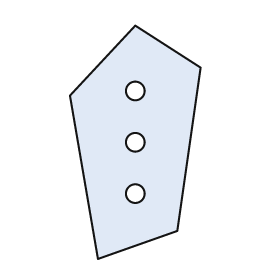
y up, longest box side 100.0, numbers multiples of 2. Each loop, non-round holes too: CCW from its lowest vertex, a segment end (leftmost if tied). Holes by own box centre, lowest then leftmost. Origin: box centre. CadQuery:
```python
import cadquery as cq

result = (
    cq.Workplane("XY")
    .moveTo(-16.0, -50.0)
    .lineTo(18.0, -38.0)
    .lineTo(28.0, 32.0)
    .lineTo(0.0, 50.0)
    .lineTo(-28.0, 20.0)
    .close()
    .moveTo(0.0, -22.0)
    .circle(4.0)
    .moveTo(0.0, 0.0)
    .circle(4.0)
    .moveTo(0.0, 22.0)
    .circle(4.0)
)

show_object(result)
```